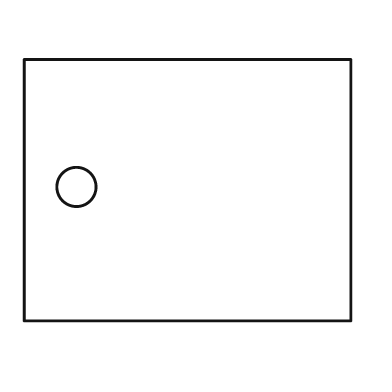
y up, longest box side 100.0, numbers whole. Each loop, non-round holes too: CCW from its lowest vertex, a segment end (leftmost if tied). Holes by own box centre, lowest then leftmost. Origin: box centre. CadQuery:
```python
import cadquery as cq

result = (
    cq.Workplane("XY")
    .moveTo(-50.0, -40.0)
    .lineTo(50.0, -40.0)
    .lineTo(50.0, 40.0)
    .lineTo(-50.0, 40.0)
    .close()
    .moveTo(-34.0, 1.0)
    .circle(6.0)
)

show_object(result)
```